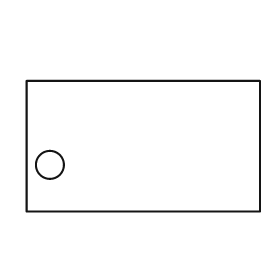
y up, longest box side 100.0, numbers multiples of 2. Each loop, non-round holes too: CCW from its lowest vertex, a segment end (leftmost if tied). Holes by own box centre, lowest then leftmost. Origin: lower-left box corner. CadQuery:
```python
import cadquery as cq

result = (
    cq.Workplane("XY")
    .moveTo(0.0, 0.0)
    .lineTo(100.0, 0.0)
    .lineTo(100.0, 56.0)
    .lineTo(0.0, 56.0)
    .close()
    .moveTo(10.0, 20.0)
    .circle(6.0)
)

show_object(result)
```